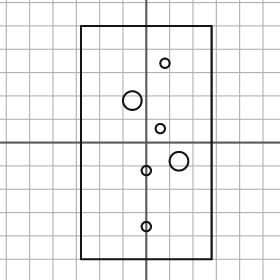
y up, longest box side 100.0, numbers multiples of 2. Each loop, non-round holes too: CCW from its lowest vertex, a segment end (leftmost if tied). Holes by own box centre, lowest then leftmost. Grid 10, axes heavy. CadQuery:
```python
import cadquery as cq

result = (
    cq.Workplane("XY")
    .moveTo(-28.0, -50.0)
    .lineTo(28.0, -50.0)
    .lineTo(28.0, 50.0)
    .lineTo(-28.0, 50.0)
    .close()
    .moveTo(0.0, -36.0)
    .circle(2.0)
    .moveTo(0.0, -12.0)
    .circle(2.0)
    .moveTo(14.0, -8.0)
    .circle(4.0)
    .moveTo(6.0, 6.0)
    .circle(2.0)
    .moveTo(-6.0, 18.0)
    .circle(4.0)
    .moveTo(8.0, 34.0)
    .circle(2.0)
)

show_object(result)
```